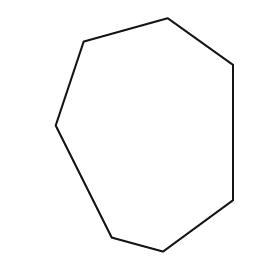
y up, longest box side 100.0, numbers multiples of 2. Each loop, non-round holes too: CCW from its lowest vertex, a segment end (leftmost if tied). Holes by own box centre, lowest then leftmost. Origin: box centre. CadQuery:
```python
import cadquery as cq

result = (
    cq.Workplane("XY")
    .moveTo(8.0, -50.0)
    .lineTo(38.0, -28.0)
    .lineTo(38.0, 30.0)
    .lineTo(10.0, 50.0)
    .lineTo(-26.0, 40.0)
    .lineTo(-38.0, 4.0)
    .lineTo(-14.0, -44.0)
    .close()
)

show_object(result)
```